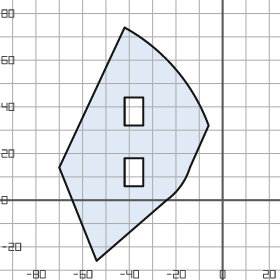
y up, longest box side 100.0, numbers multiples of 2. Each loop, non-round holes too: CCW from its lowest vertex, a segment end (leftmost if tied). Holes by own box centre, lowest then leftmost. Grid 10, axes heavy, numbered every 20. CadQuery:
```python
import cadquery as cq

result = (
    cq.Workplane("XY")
    .moveTo(-54.0, -26.0)
    .lineTo(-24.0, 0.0)
    .threePointArc((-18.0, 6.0), (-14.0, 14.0))
    .lineTo(-6.0, 32.0)
    .threePointArc((-20.0, 56.0), (-42.0, 74.0))
    .lineTo(-70.0, 14.0)
    .close()
    .moveTo(-42.0, 6.0)
    .lineTo(-34.0, 6.0)
    .lineTo(-34.0, 18.0)
    .lineTo(-42.0, 18.0)
    .close()
    .moveTo(-42.0, 32.0)
    .lineTo(-34.0, 32.0)
    .lineTo(-34.0, 44.0)
    .lineTo(-42.0, 44.0)
    .close()
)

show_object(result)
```